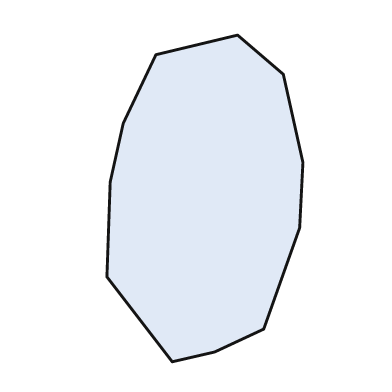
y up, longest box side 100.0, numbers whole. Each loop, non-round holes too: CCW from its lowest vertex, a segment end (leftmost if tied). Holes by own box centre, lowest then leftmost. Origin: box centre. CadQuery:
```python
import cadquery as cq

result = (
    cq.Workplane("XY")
    .moveTo(-10.0, -50.0)
    .lineTo(3.0, -47.0)
    .lineTo(18.0, -40.0)
    .lineTo(29.0, -9.0)
    .lineTo(30.0, 11.0)
    .lineTo(24.0, 38.0)
    .lineTo(10.0, 50.0)
    .lineTo(-15.0, 44.0)
    .lineTo(-25.0, 23.0)
    .lineTo(-29.0, 5.0)
    .lineTo(-30.0, -24.0)
    .close()
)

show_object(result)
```